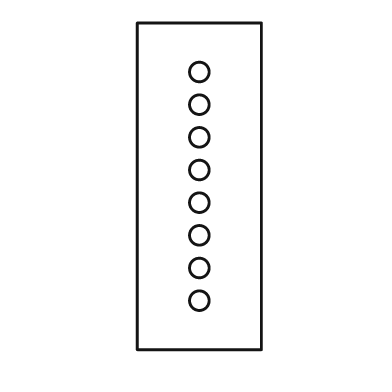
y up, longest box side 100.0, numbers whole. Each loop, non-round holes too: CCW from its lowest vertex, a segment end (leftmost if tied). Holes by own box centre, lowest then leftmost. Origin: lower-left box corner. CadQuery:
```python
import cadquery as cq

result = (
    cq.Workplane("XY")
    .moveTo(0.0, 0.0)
    .lineTo(38.0, 0.0)
    .lineTo(38.0, 100.0)
    .lineTo(0.0, 100.0)
    .close()
    .moveTo(19.0, 15.0)
    .circle(3.0)
    .moveTo(19.0, 25.0)
    .circle(3.0)
    .moveTo(19.0, 35.0)
    .circle(3.0)
    .moveTo(19.0, 45.0)
    .circle(3.0)
    .moveTo(19.0, 55.0)
    .circle(3.0)
    .moveTo(19.0, 65.0)
    .circle(3.0)
    .moveTo(19.0, 75.0)
    .circle(3.0)
    .moveTo(19.0, 85.0)
    .circle(3.0)
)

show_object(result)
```